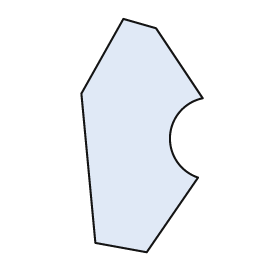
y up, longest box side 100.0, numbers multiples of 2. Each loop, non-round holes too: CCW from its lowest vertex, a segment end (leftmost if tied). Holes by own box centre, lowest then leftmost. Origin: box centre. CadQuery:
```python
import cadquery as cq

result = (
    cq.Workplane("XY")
    .moveTo(2.0, -50.0)
    .lineTo(24.0, -18.0)
    .threePointArc((12.0, 0.0), (26.0, 16.0))
    .lineTo(6.0, 46.0)
    .lineTo(-8.0, 50.0)
    .lineTo(-26.0, 18.0)
    .lineTo(-20.0, -46.0)
    .close()
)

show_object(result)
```